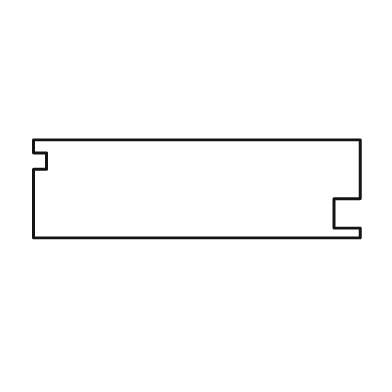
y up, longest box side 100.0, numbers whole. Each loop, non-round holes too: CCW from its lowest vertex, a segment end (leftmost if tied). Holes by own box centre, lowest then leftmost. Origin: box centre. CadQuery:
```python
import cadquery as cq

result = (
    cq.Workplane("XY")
    .moveTo(-50.0, -15.0)
    .lineTo(50.0, -15.0)
    .lineTo(50.0, -12.0)
    .lineTo(42.0, -12.0)
    .lineTo(42.0, -3.0)
    .lineTo(50.0, -3.0)
    .lineTo(50.0, 15.0)
    .lineTo(-50.0, 15.0)
    .lineTo(-50.0, 11.0)
    .lineTo(-46.0, 11.0)
    .lineTo(-46.0, 6.0)
    .lineTo(-50.0, 6.0)
    .close()
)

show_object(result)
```